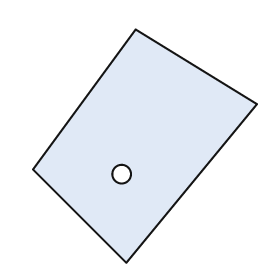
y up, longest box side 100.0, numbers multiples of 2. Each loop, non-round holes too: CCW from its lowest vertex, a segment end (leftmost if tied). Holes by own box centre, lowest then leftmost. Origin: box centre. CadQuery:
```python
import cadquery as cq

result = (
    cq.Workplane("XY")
    .moveTo(-8.0, -50.0)
    .lineTo(48.0, 18.0)
    .lineTo(-4.0, 50.0)
    .lineTo(-48.0, -10.0)
    .close()
    .moveTo(-10.0, -12.0)
    .circle(4.0)
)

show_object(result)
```